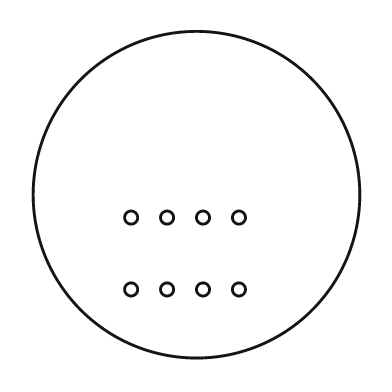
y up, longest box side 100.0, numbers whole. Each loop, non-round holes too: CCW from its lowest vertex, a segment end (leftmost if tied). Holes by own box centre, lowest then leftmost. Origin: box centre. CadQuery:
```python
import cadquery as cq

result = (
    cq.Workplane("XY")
    .moveTo(0.0, 0.0)
    .circle(50.0)
    .moveTo(-20.0, -29.0)
    .circle(2.0)
    .moveTo(-9.0, -29.0)
    .circle(2.0)
    .moveTo(2.0, -29.0)
    .circle(2.0)
    .moveTo(13.0, -29.0)
    .circle(2.0)
    .moveTo(-20.0, -7.0)
    .circle(2.0)
    .moveTo(-9.0, -7.0)
    .circle(2.0)
    .moveTo(2.0, -7.0)
    .circle(2.0)
    .moveTo(13.0, -7.0)
    .circle(2.0)
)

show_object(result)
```